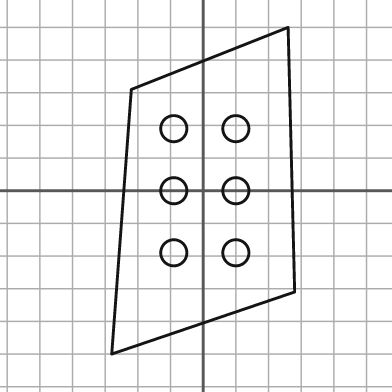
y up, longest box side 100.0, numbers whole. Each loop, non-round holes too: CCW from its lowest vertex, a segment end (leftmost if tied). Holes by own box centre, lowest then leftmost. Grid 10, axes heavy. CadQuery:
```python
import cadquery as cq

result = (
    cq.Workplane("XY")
    .moveTo(-28.0, -50.0)
    .lineTo(28.0, -31.0)
    .lineTo(26.0, 50.0)
    .lineTo(-22.0, 31.0)
    .close()
    .moveTo(-9.0, -19.0)
    .circle(4.0)
    .moveTo(10.0, -19.0)
    .circle(4.0)
    .moveTo(-9.0, 0.0)
    .circle(4.0)
    .moveTo(10.0, 0.0)
    .circle(4.0)
    .moveTo(-9.0, 19.0)
    .circle(4.0)
    .moveTo(10.0, 19.0)
    .circle(4.0)
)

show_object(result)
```